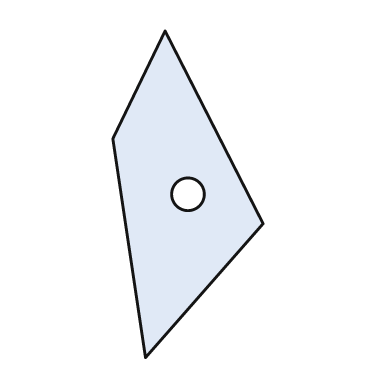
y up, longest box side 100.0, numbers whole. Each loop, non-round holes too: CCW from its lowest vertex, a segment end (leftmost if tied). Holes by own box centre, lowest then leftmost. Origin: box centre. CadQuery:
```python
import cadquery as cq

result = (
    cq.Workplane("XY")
    .moveTo(-13.0, -50.0)
    .lineTo(23.0, -9.0)
    .lineTo(-7.0, 50.0)
    .lineTo(-23.0, 17.0)
    .close()
    .moveTo(0.0, 0.0)
    .circle(5.0)
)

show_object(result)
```